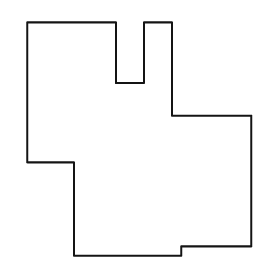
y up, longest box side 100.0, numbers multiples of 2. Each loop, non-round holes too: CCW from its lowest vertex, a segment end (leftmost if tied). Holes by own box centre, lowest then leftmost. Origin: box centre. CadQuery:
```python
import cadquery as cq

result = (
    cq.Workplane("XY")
    .moveTo(-28.0, -50.0)
    .lineTo(18.0, -50.0)
    .lineTo(18.0, -46.0)
    .lineTo(48.0, -46.0)
    .lineTo(48.0, 10.0)
    .lineTo(14.0, 10.0)
    .lineTo(14.0, 50.0)
    .lineTo(2.0, 50.0)
    .lineTo(2.0, 24.0)
    .lineTo(-10.0, 24.0)
    .lineTo(-10.0, 50.0)
    .lineTo(-48.0, 50.0)
    .lineTo(-48.0, -10.0)
    .lineTo(-28.0, -10.0)
    .close()
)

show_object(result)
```